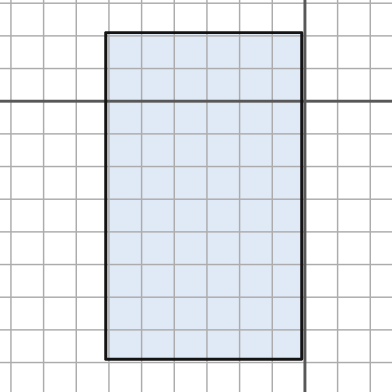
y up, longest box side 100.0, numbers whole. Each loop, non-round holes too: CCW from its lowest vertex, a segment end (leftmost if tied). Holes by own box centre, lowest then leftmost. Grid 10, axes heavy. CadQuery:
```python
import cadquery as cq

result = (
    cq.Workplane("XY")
    .moveTo(-61.0, -79.0)
    .lineTo(-1.0, -79.0)
    .lineTo(-1.0, 21.0)
    .lineTo(-61.0, 21.0)
    .close()
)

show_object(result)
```